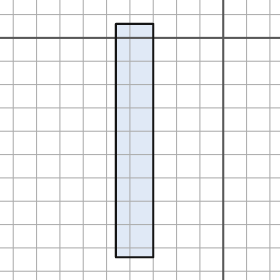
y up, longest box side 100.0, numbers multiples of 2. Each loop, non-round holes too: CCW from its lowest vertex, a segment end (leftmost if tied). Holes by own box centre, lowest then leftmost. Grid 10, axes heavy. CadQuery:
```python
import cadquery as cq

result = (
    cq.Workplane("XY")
    .moveTo(-46.0, -94.0)
    .lineTo(-30.0, -94.0)
    .lineTo(-30.0, 6.0)
    .lineTo(-46.0, 6.0)
    .close()
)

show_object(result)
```